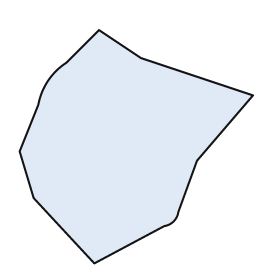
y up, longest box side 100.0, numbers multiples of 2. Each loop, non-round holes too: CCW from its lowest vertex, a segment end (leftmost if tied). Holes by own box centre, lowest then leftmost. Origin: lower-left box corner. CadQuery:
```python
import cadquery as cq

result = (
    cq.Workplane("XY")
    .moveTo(32.0, 0.0)
    .lineTo(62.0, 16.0)
    .threePointArc((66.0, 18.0), (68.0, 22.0))
    .lineTo(76.0, 44.0)
    .lineTo(100.0, 72.0)
    .lineTo(52.0, 88.0)
    .lineTo(34.0, 100.0)
    .lineTo(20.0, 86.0)
    .threePointArc((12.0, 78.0), (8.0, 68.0))
    .lineTo(0.0, 48.0)
    .lineTo(6.0, 28.0)
    .close()
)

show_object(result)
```